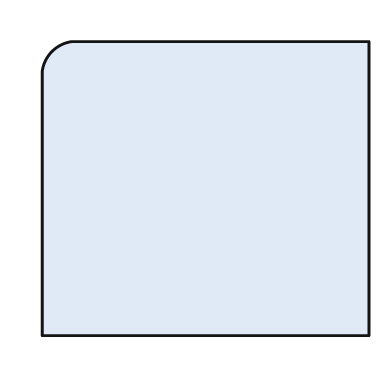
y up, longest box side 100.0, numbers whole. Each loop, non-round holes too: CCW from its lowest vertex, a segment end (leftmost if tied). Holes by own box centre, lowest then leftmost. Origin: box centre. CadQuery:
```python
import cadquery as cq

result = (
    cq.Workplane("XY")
    .moveTo(-50.0, -45.0)
    .lineTo(50.0, -45.0)
    .lineTo(50.0, 45.0)
    .lineTo(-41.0, 45.0)
    .threePointArc((-47.0, 42.0), (-50.0, 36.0))
    .close()
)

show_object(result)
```